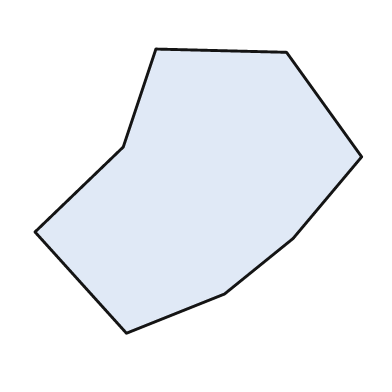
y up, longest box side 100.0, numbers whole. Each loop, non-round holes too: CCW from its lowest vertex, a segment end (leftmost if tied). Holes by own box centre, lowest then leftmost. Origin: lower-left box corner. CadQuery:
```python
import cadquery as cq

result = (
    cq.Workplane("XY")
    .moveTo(28.0, 0.0)
    .lineTo(58.0, 12.0)
    .lineTo(79.0, 29.0)
    .lineTo(100.0, 54.0)
    .lineTo(77.0, 86.0)
    .lineTo(37.0, 87.0)
    .lineTo(27.0, 57.0)
    .lineTo(0.0, 31.0)
    .close()
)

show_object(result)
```